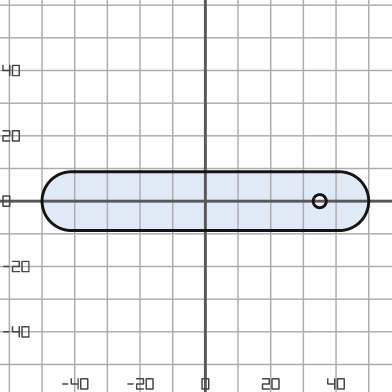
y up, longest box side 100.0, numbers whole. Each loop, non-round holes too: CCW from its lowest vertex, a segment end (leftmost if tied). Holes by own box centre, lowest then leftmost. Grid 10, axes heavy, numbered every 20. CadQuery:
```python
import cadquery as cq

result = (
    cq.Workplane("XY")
    .moveTo(-41.0, -9.0)
    .lineTo(41.0, -9.0)
    .threePointArc((50.0, 0.0), (41.0, 9.0))
    .lineTo(-41.0, 9.0)
    .threePointArc((-50.0, 0.0), (-41.0, -9.0))
    .close()
    .moveTo(35.0, 0.0)
    .circle(2.0)
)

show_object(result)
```